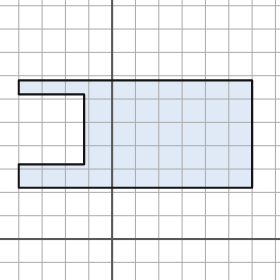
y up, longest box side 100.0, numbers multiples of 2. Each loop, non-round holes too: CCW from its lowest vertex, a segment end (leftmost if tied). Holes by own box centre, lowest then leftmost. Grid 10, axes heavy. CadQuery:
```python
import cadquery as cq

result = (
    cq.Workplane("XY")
    .moveTo(-40.0, 22.0)
    .lineTo(60.0, 22.0)
    .lineTo(60.0, 68.0)
    .lineTo(-40.0, 68.0)
    .lineTo(-40.0, 62.0)
    .lineTo(-12.0, 62.0)
    .lineTo(-12.0, 32.0)
    .lineTo(-40.0, 32.0)
    .close()
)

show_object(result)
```